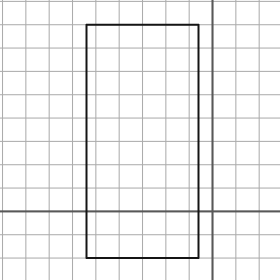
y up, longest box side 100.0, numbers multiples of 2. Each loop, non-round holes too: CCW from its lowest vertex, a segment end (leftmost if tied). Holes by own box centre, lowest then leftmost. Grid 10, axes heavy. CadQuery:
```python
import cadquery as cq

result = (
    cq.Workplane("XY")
    .moveTo(-54.0, -20.0)
    .lineTo(-6.0, -20.0)
    .lineTo(-6.0, 80.0)
    .lineTo(-54.0, 80.0)
    .close()
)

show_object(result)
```